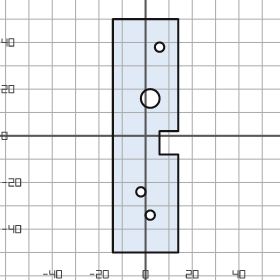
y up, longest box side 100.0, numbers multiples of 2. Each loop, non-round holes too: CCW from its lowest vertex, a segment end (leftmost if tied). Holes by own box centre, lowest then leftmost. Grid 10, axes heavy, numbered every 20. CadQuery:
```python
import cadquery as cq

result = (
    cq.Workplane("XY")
    .moveTo(-14.0, -50.0)
    .lineTo(14.0, -50.0)
    .lineTo(14.0, -8.0)
    .lineTo(6.0, -8.0)
    .lineTo(6.0, 2.0)
    .lineTo(14.0, 2.0)
    .lineTo(14.0, 50.0)
    .lineTo(-14.0, 50.0)
    .close()
    .moveTo(2.0, -34.0)
    .circle(2.0)
    .moveTo(-2.0, -24.0)
    .circle(2.0)
    .moveTo(2.0, 16.0)
    .circle(4.0)
    .moveTo(6.0, 38.0)
    .circle(2.0)
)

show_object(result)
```